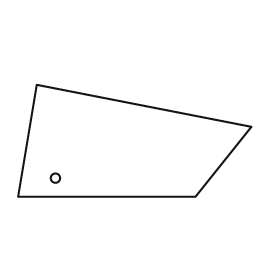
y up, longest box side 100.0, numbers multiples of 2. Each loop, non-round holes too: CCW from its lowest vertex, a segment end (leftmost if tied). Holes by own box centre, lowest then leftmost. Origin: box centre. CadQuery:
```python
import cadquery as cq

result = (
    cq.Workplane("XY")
    .moveTo(-50.0, -24.0)
    .lineTo(26.0, -24.0)
    .lineTo(50.0, 6.0)
    .lineTo(-42.0, 24.0)
    .close()
    .moveTo(-34.0, -16.0)
    .circle(2.0)
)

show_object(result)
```